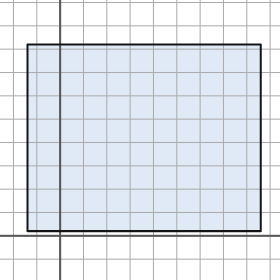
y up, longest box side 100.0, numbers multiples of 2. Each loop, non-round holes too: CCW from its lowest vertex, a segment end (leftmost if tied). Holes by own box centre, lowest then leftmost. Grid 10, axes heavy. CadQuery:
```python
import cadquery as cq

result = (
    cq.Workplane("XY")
    .moveTo(-14.0, 2.0)
    .lineTo(86.0, 2.0)
    .lineTo(86.0, 82.0)
    .lineTo(-14.0, 82.0)
    .close()
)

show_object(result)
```